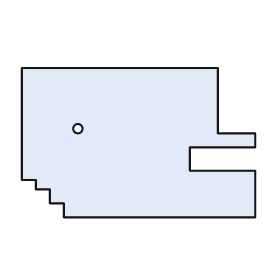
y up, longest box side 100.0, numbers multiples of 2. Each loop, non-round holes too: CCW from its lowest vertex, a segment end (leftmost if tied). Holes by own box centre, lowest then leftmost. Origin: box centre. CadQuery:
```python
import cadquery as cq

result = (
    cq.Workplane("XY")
    .moveTo(-32.0, -32.0)
    .lineTo(50.0, -32.0)
    .lineTo(50.0, -12.0)
    .lineTo(22.0, -12.0)
    .lineTo(22.0, -2.0)
    .lineTo(50.0, -2.0)
    .lineTo(50.0, 4.0)
    .lineTo(34.0, 4.0)
    .lineTo(34.0, 32.0)
    .lineTo(-50.0, 32.0)
    .lineTo(-50.0, -16.0)
    .lineTo(-44.0, -16.0)
    .lineTo(-44.0, -20.0)
    .lineTo(-38.0, -20.0)
    .lineTo(-38.0, -26.0)
    .lineTo(-32.0, -26.0)
    .close()
    .moveTo(-26.0, 6.0)
    .circle(2.0)
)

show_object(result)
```